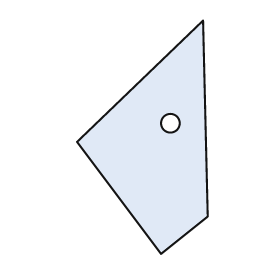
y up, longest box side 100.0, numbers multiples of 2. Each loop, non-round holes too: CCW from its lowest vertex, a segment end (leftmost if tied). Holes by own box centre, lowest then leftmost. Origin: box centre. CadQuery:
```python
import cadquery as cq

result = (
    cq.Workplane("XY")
    .moveTo(8.0, -50.0)
    .lineTo(28.0, -34.0)
    .lineTo(26.0, 50.0)
    .lineTo(-28.0, -2.0)
    .close()
    .moveTo(12.0, 6.0)
    .circle(4.0)
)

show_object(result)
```